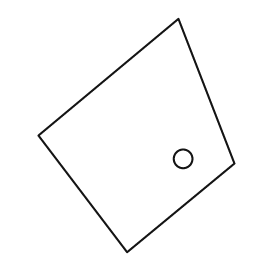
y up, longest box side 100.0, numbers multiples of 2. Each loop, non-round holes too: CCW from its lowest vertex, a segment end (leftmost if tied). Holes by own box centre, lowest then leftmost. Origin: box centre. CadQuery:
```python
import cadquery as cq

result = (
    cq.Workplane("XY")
    .moveTo(-4.0, -50.0)
    .lineTo(42.0, -12.0)
    .lineTo(18.0, 50.0)
    .lineTo(-42.0, 0.0)
    .close()
    .moveTo(20.0, -10.0)
    .circle(4.0)
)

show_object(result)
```